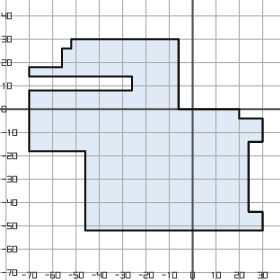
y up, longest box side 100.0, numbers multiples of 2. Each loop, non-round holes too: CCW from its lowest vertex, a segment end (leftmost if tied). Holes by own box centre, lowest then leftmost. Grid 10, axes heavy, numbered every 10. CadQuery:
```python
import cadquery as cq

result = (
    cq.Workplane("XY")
    .moveTo(-46.0, -52.0)
    .lineTo(30.0, -52.0)
    .lineTo(30.0, -44.0)
    .lineTo(24.0, -44.0)
    .lineTo(24.0, -14.0)
    .lineTo(30.0, -14.0)
    .lineTo(30.0, -4.0)
    .lineTo(20.0, -4.0)
    .lineTo(20.0, 0.0)
    .lineTo(-6.0, 0.0)
    .lineTo(-6.0, 30.0)
    .lineTo(-52.0, 30.0)
    .lineTo(-52.0, 26.0)
    .lineTo(-56.0, 26.0)
    .lineTo(-56.0, 18.0)
    .lineTo(-70.0, 18.0)
    .lineTo(-70.0, 14.0)
    .lineTo(-26.0, 14.0)
    .lineTo(-26.0, 8.0)
    .lineTo(-70.0, 8.0)
    .lineTo(-70.0, -18.0)
    .lineTo(-46.0, -18.0)
    .close()
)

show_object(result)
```